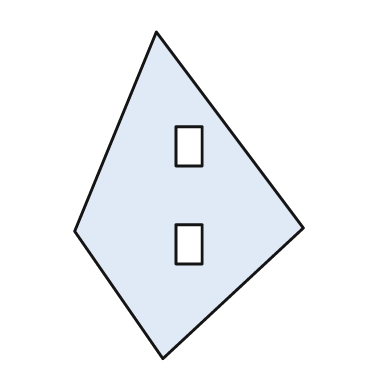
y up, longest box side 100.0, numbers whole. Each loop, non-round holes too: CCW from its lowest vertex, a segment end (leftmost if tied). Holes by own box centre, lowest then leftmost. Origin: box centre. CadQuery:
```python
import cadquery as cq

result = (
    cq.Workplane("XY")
    .moveTo(-8.0, -50.0)
    .lineTo(35.0, -10.0)
    .lineTo(-10.0, 50.0)
    .lineTo(-35.0, -11.0)
    .close()
    .moveTo(-4.0, -21.0)
    .lineTo(4.0, -21.0)
    .lineTo(4.0, -9.0)
    .lineTo(-4.0, -9.0)
    .close()
    .moveTo(-4.0, 9.0)
    .lineTo(4.0, 9.0)
    .lineTo(4.0, 21.0)
    .lineTo(-4.0, 21.0)
    .close()
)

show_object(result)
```